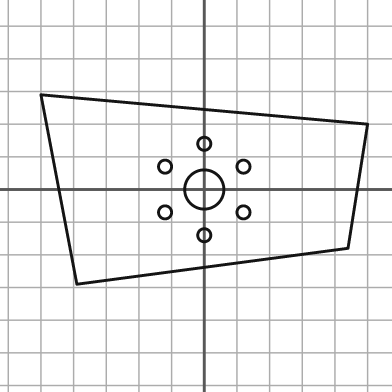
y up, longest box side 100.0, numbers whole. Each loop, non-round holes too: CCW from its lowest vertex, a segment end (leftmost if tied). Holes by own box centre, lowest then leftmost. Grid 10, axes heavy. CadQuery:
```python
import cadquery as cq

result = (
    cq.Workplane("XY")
    .moveTo(-39.0, -29.0)
    .lineTo(44.0, -18.0)
    .lineTo(50.0, 20.0)
    .lineTo(-50.0, 29.0)
    .close()
    .moveTo(0.0, -14.0)
    .circle(2.0)
    .moveTo(-12.0, -7.0)
    .circle(2.0)
    .moveTo(12.0, -7.0)
    .circle(2.0)
    .moveTo(0.0, 0.0)
    .circle(6.0)
    .moveTo(-12.0, 7.0)
    .circle(2.0)
    .moveTo(12.0, 7.0)
    .circle(2.0)
    .moveTo(0.0, 14.0)
    .circle(2.0)
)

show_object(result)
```